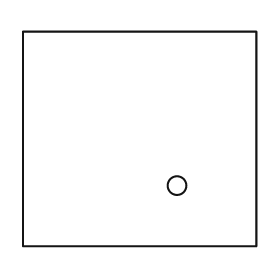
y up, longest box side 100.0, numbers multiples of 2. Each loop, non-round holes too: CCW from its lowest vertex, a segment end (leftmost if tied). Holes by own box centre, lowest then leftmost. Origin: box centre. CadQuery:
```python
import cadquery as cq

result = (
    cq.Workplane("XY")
    .moveTo(-50.0, -46.0)
    .lineTo(50.0, -46.0)
    .lineTo(50.0, 46.0)
    .lineTo(-50.0, 46.0)
    .close()
    .moveTo(16.0, -20.0)
    .circle(4.0)
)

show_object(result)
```